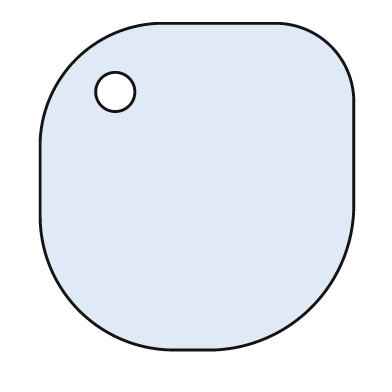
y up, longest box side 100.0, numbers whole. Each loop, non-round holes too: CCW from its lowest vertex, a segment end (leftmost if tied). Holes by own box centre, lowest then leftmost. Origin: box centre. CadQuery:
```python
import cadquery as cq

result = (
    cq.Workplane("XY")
    .moveTo(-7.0, -50.0)
    .lineTo(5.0, -50.0)
    .threePointArc((35.0, -37.0), (48.0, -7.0))
    .lineTo(48.0, 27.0)
    .threePointArc((41.0, 43.0), (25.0, 50.0))
    .lineTo(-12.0, 50.0)
    .threePointArc((-37.0, 39.0), (-48.0, 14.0))
    .lineTo(-48.0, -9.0)
    .threePointArc((-36.0, -38.0), (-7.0, -50.0))
    .close()
    .moveTo(-25.0, 29.0)
    .circle(6.0)
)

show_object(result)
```